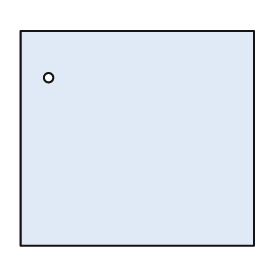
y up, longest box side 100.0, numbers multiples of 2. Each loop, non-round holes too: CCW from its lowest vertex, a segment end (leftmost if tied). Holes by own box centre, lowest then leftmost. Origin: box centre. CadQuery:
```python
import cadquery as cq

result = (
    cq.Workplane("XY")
    .moveTo(-50.0, -46.0)
    .lineTo(50.0, -46.0)
    .lineTo(50.0, 46.0)
    .lineTo(-50.0, 46.0)
    .close()
    .moveTo(-38.0, 26.0)
    .circle(2.0)
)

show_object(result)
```